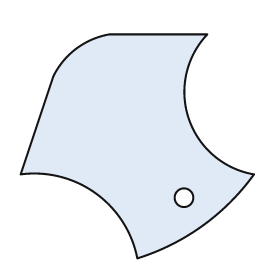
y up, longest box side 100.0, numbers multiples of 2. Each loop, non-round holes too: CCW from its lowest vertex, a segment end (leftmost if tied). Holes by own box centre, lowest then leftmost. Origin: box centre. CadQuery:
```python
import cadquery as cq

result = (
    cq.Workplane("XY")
    .moveTo(0.0, -48.0)
    .threePointArc((28.0, -34.0), (50.0, -12.0))
    .threePointArc((22.0, 12.0), (30.0, 48.0))
    .lineTo(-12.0, 48.0)
    .threePointArc((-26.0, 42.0), (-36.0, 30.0))
    .lineTo(-50.0, -12.0)
    .threePointArc((-18.0, -20.0), (0.0, -48.0))
    .close()
    .moveTo(20.0, -22.0)
    .circle(4.0)
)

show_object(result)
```